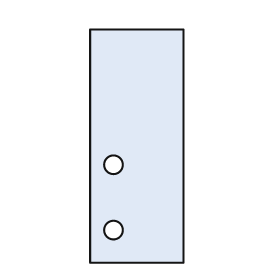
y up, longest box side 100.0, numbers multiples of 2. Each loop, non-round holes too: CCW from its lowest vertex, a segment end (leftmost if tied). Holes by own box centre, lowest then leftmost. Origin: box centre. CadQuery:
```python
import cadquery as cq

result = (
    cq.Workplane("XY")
    .moveTo(-20.0, -50.0)
    .lineTo(20.0, -50.0)
    .lineTo(20.0, 50.0)
    .lineTo(-20.0, 50.0)
    .close()
    .moveTo(-10.0, -36.0)
    .circle(4.0)
    .moveTo(-10.0, -8.0)
    .circle(4.0)
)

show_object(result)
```